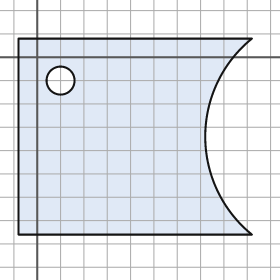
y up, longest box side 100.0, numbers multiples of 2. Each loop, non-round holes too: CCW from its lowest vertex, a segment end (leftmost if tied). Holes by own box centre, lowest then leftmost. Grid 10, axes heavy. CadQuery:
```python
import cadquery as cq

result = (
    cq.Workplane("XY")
    .moveTo(-8.0, -76.0)
    .lineTo(92.0, -76.0)
    .threePointArc((72.0, -34.0), (92.0, 8.0))
    .lineTo(-8.0, 8.0)
    .close()
    .moveTo(10.0, -10.0)
    .circle(6.0)
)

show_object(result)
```